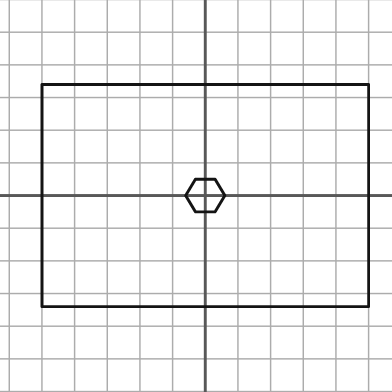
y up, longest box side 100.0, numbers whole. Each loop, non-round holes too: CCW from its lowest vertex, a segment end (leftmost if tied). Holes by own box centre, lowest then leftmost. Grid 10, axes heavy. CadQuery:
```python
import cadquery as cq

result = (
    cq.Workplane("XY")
    .moveTo(-50.0, -34.0)
    .lineTo(50.0, -34.0)
    .lineTo(50.0, 34.0)
    .lineTo(-50.0, 34.0)
    .close()
    .moveTo(-3.0, -5.0)
    .lineTo(3.0, -5.0)
    .lineTo(6.0, 0.0)
    .lineTo(3.0, 5.0)
    .lineTo(-3.0, 5.0)
    .lineTo(-6.0, 0.0)
    .close()
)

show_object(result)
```